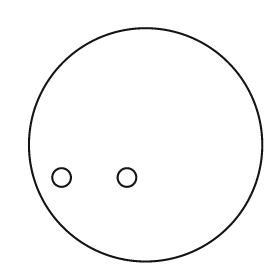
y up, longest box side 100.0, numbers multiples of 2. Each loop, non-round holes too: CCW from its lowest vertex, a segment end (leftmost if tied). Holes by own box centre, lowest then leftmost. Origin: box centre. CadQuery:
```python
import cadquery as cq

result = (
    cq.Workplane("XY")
    .moveTo(0.0, 0.0)
    .circle(50.0)
    .moveTo(-36.0, -14.0)
    .circle(4.0)
    .moveTo(-8.0, -14.0)
    .circle(4.0)
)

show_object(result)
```